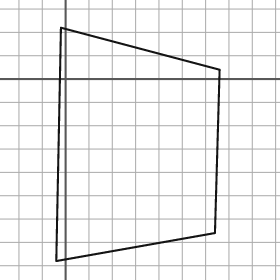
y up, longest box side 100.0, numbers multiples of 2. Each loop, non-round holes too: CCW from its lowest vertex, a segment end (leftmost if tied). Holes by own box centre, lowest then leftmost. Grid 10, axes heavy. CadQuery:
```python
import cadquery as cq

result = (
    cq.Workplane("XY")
    .moveTo(-4.0, -78.0)
    .lineTo(64.0, -66.0)
    .lineTo(66.0, 4.0)
    .lineTo(-2.0, 22.0)
    .close()
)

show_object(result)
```